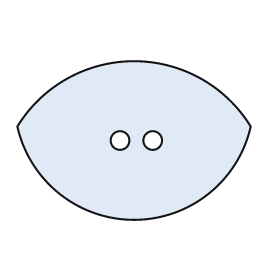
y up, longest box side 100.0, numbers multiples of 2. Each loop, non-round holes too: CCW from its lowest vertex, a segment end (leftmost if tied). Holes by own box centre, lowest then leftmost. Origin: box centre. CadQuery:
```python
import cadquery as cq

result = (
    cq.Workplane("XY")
    .moveTo(-50.0, 6.0)
    .threePointArc((0.0, -34.0), (50.0, 6.0))
    .threePointArc((0.0, 34.0), (-50.0, 6.0))
    .close()
    .moveTo(-6.0, 0.0)
    .circle(4.0)
    .moveTo(8.0, 0.0)
    .circle(4.0)
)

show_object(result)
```